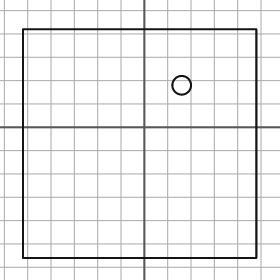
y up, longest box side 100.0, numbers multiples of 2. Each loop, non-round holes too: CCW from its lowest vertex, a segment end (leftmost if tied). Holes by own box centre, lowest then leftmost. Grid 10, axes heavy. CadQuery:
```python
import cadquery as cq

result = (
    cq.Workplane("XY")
    .moveTo(-52.0, -56.0)
    .lineTo(48.0, -56.0)
    .lineTo(48.0, 42.0)
    .lineTo(-52.0, 42.0)
    .close()
    .moveTo(16.0, 18.0)
    .circle(4.0)
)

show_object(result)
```